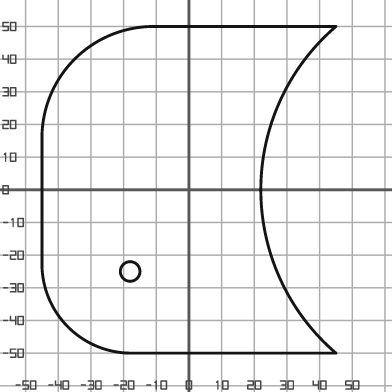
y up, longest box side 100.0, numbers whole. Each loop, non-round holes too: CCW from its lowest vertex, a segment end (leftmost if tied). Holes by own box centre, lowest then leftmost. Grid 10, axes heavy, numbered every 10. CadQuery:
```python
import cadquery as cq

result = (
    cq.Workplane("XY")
    .moveTo(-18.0, -50.0)
    .lineTo(45.0, -50.0)
    .threePointArc((22.0, 0.0), (45.0, 50.0))
    .lineTo(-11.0, 50.0)
    .threePointArc((-35.0, 40.0), (-45.0, 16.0))
    .lineTo(-45.0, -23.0)
    .threePointArc((-37.0, -42.0), (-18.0, -50.0))
    .close()
    .moveTo(-18.0, -25.0)
    .circle(3.0)
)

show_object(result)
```